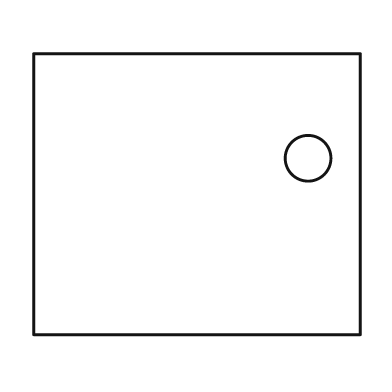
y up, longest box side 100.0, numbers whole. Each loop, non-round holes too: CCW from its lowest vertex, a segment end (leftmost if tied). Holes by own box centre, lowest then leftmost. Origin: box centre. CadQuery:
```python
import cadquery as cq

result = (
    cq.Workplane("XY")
    .moveTo(-50.0, -43.0)
    .lineTo(50.0, -43.0)
    .lineTo(50.0, 43.0)
    .lineTo(-50.0, 43.0)
    .close()
    .moveTo(34.0, 11.0)
    .circle(7.0)
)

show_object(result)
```